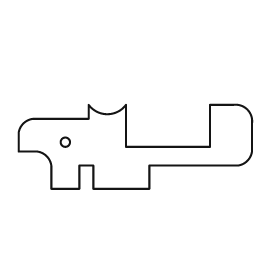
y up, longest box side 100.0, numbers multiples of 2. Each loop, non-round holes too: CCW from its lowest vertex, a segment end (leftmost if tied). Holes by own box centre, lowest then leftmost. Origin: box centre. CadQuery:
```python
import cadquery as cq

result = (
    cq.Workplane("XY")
    .moveTo(-36.0, -18.0)
    .lineTo(-24.0, -18.0)
    .lineTo(-24.0, -8.0)
    .lineTo(-18.0, -8.0)
    .lineTo(-18.0, -18.0)
    .lineTo(6.0, -18.0)
    .lineTo(6.0, -8.0)
    .lineTo(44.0, -8.0)
    .threePointArc((48.0, -6.0), (50.0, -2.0))
    .lineTo(50.0, 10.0)
    .threePointArc((48.0, 16.0), (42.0, 18.0))
    .lineTo(32.0, 18.0)
    .lineTo(32.0, 0.0)
    .lineTo(-4.0, 0.0)
    .lineTo(-4.0, 18.0)
    .threePointArc((-12.0, 14.0), (-20.0, 18.0))
    .lineTo(-20.0, 12.0)
    .lineTo(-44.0, 12.0)
    .threePointArc((-48.0, 10.0), (-50.0, 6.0))
    .lineTo(-50.0, -2.0)
    .lineTo(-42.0, -2.0)
    .threePointArc((-38.0, -4.0), (-36.0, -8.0))
    .close()
    .moveTo(-30.0, 2.0)
    .circle(2.0)
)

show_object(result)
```